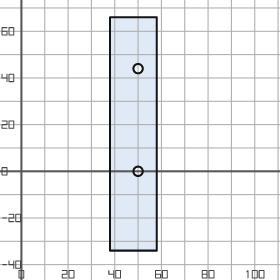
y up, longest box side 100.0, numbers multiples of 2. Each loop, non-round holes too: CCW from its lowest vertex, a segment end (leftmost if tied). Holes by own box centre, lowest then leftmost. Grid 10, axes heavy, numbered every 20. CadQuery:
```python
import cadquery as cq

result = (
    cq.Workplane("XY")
    .moveTo(38.0, -34.0)
    .lineTo(58.0, -34.0)
    .lineTo(58.0, 66.0)
    .lineTo(38.0, 66.0)
    .close()
    .moveTo(50.0, 0.0)
    .circle(2.0)
    .moveTo(50.0, 44.0)
    .circle(2.0)
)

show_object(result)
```